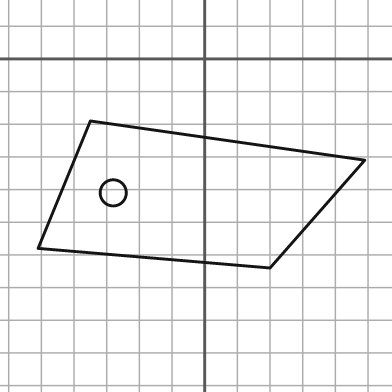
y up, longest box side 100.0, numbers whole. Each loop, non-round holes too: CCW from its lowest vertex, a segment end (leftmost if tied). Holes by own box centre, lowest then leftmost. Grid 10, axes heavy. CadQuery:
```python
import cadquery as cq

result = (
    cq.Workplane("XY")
    .moveTo(20.0, -64.0)
    .lineTo(49.0, -31.0)
    .lineTo(-35.0, -19.0)
    .lineTo(-51.0, -58.0)
    .close()
    .moveTo(-28.0, -41.0)
    .circle(4.0)
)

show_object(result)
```